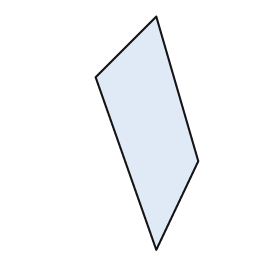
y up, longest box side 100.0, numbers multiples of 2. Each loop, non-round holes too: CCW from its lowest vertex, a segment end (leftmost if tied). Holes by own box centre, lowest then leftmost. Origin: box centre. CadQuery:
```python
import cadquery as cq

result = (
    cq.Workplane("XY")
    .moveTo(4.0, -50.0)
    .lineTo(22.0, -12.0)
    .lineTo(4.0, 50.0)
    .lineTo(-22.0, 24.0)
    .close()
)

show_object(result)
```